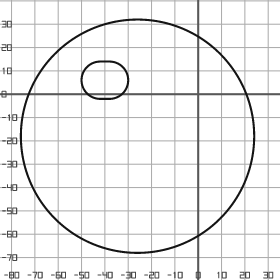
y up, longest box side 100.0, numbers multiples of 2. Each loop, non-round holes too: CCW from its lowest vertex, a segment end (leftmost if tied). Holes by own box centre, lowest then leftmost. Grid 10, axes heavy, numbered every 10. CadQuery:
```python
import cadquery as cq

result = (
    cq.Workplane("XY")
    .moveTo(-26.0, -18.0)
    .circle(50.0)
    .moveTo(-42.0, -2.0)
    .lineTo(-38.0, -2.0)
    .threePointArc((-30.0, 6.0), (-38.0, 14.0))
    .lineTo(-42.0, 14.0)
    .threePointArc((-50.0, 6.0), (-42.0, -2.0))
    .close()
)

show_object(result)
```